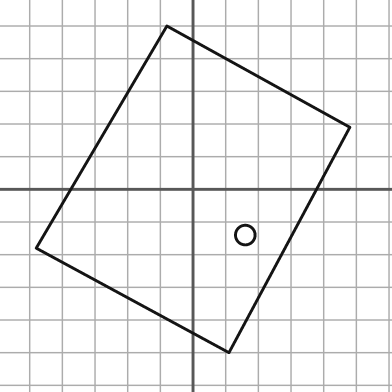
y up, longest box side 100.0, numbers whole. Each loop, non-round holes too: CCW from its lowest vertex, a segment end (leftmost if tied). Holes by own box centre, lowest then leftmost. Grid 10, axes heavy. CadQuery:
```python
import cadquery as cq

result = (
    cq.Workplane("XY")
    .moveTo(11.0, -50.0)
    .lineTo(48.0, 19.0)
    .lineTo(-8.0, 50.0)
    .lineTo(-48.0, -18.0)
    .close()
    .moveTo(16.0, -14.0)
    .circle(3.0)
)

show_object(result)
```